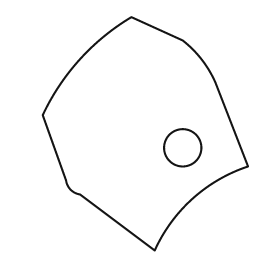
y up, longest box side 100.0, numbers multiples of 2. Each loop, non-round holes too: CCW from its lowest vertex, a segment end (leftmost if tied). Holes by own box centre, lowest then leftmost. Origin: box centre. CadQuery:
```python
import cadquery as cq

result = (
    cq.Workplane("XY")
    .moveTo(4.0, -50.0)
    .threePointArc((20.0, -28.0), (44.0, -14.0))
    .lineTo(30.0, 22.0)
    .threePointArc((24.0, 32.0), (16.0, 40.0))
    .lineTo(-6.0, 50.0)
    .threePointArc((-28.0, 32.0), (-44.0, 8.0))
    .lineTo(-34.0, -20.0)
    .threePointArc((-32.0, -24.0), (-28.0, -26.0))
    .close()
    .moveTo(16.0, -6.0)
    .circle(8.0)
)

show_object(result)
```